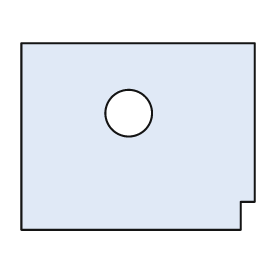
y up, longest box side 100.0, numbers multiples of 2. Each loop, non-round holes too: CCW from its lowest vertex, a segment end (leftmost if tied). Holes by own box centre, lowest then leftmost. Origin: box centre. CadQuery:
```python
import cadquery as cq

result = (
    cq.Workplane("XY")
    .moveTo(-50.0, -40.0)
    .lineTo(44.0, -40.0)
    .lineTo(44.0, -28.0)
    .lineTo(50.0, -28.0)
    .lineTo(50.0, 40.0)
    .lineTo(-50.0, 40.0)
    .close()
    .moveTo(-4.0, 10.0)
    .circle(10.0)
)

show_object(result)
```